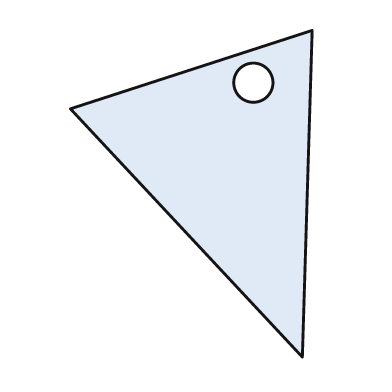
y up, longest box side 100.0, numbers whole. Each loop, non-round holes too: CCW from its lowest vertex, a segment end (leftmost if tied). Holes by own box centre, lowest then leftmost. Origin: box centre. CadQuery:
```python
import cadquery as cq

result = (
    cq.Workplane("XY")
    .moveTo(34.0, -50.0)
    .lineTo(37.0, 50.0)
    .lineTo(-37.0, 26.0)
    .close()
    .moveTo(19.0, 34.0)
    .circle(6.0)
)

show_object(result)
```